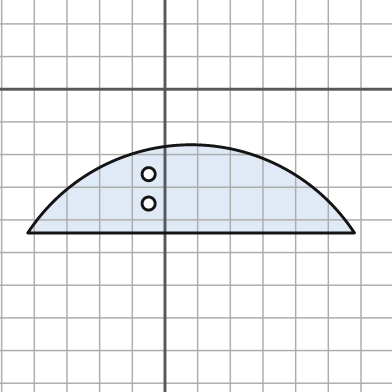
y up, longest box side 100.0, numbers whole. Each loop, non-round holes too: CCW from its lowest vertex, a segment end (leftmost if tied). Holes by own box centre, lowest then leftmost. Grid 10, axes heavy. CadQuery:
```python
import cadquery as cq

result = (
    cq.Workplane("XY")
    .moveTo(-42.0, -44.0)
    .lineTo(58.0, -44.0)
    .threePointArc((8.0, -17.0), (-42.0, -44.0))
    .close()
    .moveTo(-5.0, -35.0)
    .circle(2.0)
    .moveTo(-5.0, -26.0)
    .circle(2.0)
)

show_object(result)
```